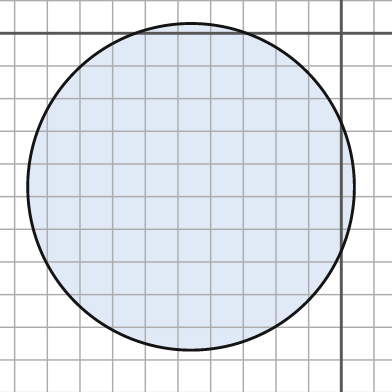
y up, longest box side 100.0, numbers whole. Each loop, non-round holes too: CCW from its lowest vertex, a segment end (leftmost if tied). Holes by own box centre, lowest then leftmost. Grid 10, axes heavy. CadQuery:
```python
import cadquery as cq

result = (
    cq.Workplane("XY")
    .moveTo(-46.0, -47.0)
    .circle(50.0)
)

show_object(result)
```